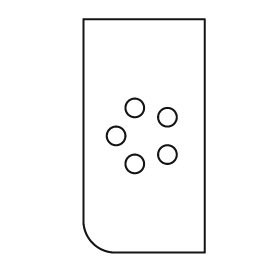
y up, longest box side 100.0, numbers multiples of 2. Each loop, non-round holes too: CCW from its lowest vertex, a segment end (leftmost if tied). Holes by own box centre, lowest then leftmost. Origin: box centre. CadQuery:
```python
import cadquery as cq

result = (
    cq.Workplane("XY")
    .moveTo(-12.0, -50.0)
    .lineTo(26.0, -50.0)
    .lineTo(26.0, 50.0)
    .lineTo(-26.0, 50.0)
    .lineTo(-26.0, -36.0)
    .threePointArc((-22.0, -46.0), (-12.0, -50.0))
    .close()
    .moveTo(-4.0, -12.0)
    .circle(4.0)
    .moveTo(10.0, -8.0)
    .circle(4.0)
    .moveTo(-12.0, 0.0)
    .circle(4.0)
    .moveTo(10.0, 8.0)
    .circle(4.0)
    .moveTo(-4.0, 12.0)
    .circle(4.0)
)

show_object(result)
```